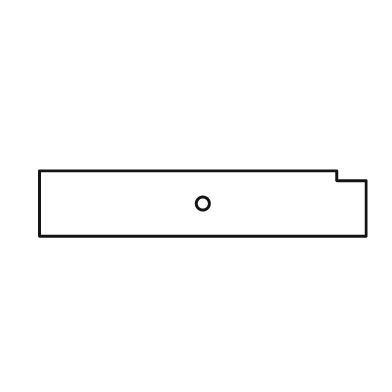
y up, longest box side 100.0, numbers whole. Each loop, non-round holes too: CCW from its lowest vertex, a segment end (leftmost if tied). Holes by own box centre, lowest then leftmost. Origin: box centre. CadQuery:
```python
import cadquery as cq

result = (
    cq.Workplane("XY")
    .moveTo(-50.0, -10.0)
    .lineTo(50.0, -10.0)
    .lineTo(50.0, 7.0)
    .lineTo(41.0, 7.0)
    .lineTo(41.0, 10.0)
    .lineTo(-50.0, 10.0)
    .close()
    .moveTo(0.0, 0.0)
    .circle(2.0)
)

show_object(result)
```